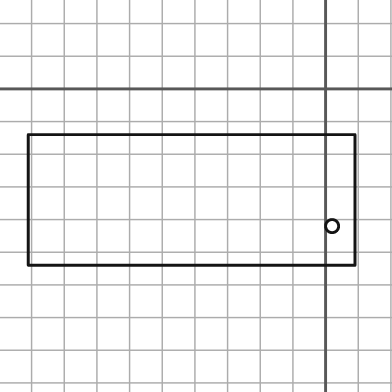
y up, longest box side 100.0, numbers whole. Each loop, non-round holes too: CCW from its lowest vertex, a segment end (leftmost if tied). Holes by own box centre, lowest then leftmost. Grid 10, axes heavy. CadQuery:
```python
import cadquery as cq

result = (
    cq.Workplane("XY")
    .moveTo(-91.0, -54.0)
    .lineTo(9.0, -54.0)
    .lineTo(9.0, -14.0)
    .lineTo(-91.0, -14.0)
    .close()
    .moveTo(2.0, -42.0)
    .circle(2.0)
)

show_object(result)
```